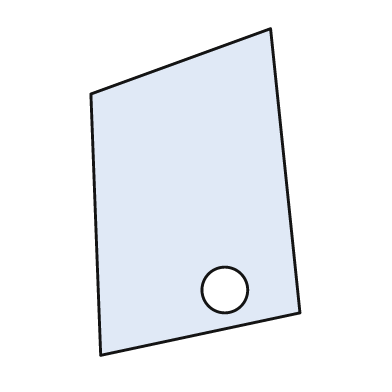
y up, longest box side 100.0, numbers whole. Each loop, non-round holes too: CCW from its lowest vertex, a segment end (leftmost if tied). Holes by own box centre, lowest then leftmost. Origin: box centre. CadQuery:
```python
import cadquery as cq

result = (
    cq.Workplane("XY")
    .moveTo(-29.0, -50.0)
    .lineTo(32.0, -37.0)
    .lineTo(23.0, 50.0)
    .lineTo(-32.0, 30.0)
    .close()
    .moveTo(9.0, -30.0)
    .circle(7.0)
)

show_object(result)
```